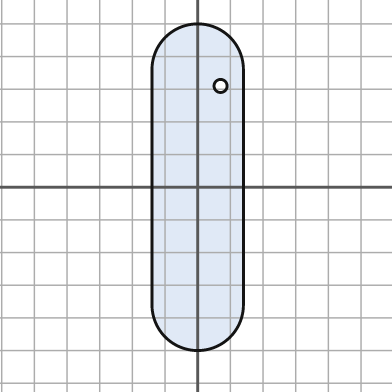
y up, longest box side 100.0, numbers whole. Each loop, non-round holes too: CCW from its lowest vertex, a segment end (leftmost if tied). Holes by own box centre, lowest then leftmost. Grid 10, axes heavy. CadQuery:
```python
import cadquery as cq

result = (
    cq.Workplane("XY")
    .moveTo(-14.0, -36.0)
    .threePointArc((0.0, -50.0), (14.0, -36.0))
    .lineTo(14.0, 36.0)
    .threePointArc((0.0, 50.0), (-14.0, 36.0))
    .close()
    .moveTo(7.0, 31.0)
    .circle(2.0)
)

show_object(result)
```